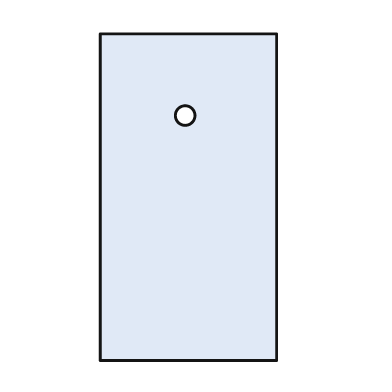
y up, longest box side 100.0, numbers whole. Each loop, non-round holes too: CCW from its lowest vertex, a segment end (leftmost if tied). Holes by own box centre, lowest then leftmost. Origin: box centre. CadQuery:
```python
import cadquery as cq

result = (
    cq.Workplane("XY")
    .moveTo(-27.0, -50.0)
    .lineTo(27.0, -50.0)
    .lineTo(27.0, 50.0)
    .lineTo(-27.0, 50.0)
    .close()
    .moveTo(-1.0, 25.0)
    .circle(3.0)
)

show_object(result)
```